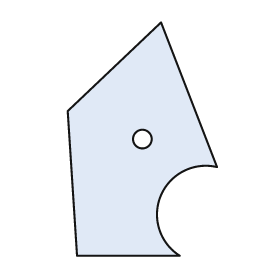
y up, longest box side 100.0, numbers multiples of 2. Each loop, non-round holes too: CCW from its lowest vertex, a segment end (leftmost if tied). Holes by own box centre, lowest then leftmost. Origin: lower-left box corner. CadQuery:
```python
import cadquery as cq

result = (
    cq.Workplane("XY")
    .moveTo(4.0, 0.0)
    .lineTo(48.0, 0.0)
    .threePointArc((40.0, 26.0), (64.0, 38.0))
    .lineTo(40.0, 100.0)
    .lineTo(0.0, 62.0)
    .close()
    .moveTo(32.0, 50.0)
    .circle(4.0)
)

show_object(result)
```